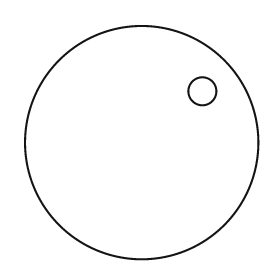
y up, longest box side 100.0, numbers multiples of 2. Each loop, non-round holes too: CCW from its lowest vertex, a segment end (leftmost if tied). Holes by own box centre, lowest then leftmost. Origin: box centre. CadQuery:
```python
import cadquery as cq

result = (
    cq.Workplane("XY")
    .moveTo(0.0, 0.0)
    .circle(50.0)
    .moveTo(26.0, 22.0)
    .circle(6.0)
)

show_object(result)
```